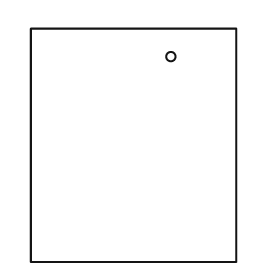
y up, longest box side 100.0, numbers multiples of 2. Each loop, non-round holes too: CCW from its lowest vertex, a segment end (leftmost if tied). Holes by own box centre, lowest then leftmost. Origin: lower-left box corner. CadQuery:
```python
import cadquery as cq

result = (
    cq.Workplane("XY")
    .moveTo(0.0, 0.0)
    .lineTo(88.0, 0.0)
    .lineTo(88.0, 100.0)
    .lineTo(0.0, 100.0)
    .close()
    .moveTo(60.0, 88.0)
    .circle(2.0)
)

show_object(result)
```